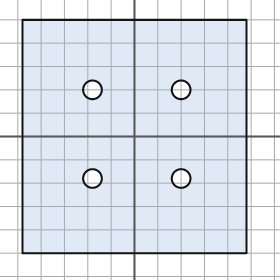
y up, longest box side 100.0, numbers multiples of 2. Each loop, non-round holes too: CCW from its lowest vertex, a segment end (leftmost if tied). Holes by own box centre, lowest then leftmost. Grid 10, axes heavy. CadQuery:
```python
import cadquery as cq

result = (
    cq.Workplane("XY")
    .moveTo(-48.0, -50.0)
    .lineTo(48.0, -50.0)
    .lineTo(48.0, 50.0)
    .lineTo(-48.0, 50.0)
    .close()
    .moveTo(-18.0, -18.0)
    .circle(4.0)
    .moveTo(20.0, -18.0)
    .circle(4.0)
    .moveTo(-18.0, 20.0)
    .circle(4.0)
    .moveTo(20.0, 20.0)
    .circle(4.0)
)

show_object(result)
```